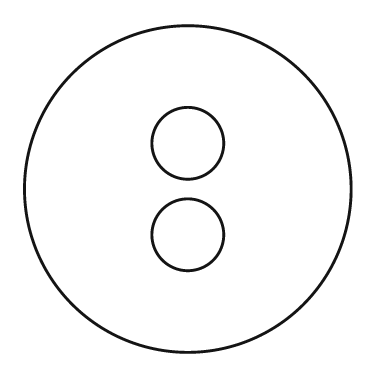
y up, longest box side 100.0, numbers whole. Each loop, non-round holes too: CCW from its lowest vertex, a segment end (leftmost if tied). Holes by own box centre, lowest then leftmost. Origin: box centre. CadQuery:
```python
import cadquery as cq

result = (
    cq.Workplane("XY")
    .moveTo(0.0, 0.0)
    .circle(50.0)
    .moveTo(0.0, -14.0)
    .circle(11.0)
    .moveTo(0.0, 14.0)
    .circle(11.0)
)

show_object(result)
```